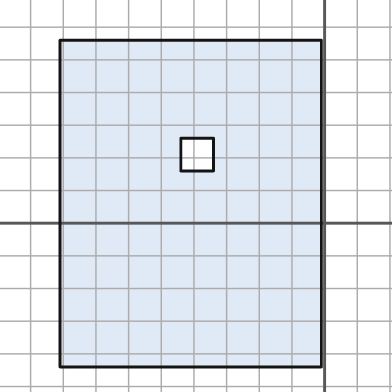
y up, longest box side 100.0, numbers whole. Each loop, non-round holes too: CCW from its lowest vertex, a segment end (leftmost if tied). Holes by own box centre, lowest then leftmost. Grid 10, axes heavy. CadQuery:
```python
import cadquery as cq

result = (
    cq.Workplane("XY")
    .moveTo(-81.0, -44.0)
    .lineTo(-1.0, -44.0)
    .lineTo(-1.0, 56.0)
    .lineTo(-81.0, 56.0)
    .close()
    .moveTo(-44.0, 16.0)
    .lineTo(-34.0, 16.0)
    .lineTo(-34.0, 26.0)
    .lineTo(-44.0, 26.0)
    .close()
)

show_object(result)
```